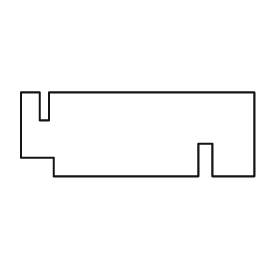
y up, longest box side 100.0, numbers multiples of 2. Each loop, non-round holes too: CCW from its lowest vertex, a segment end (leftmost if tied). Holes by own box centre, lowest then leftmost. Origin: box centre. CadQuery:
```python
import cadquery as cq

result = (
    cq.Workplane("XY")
    .moveTo(-36.0, -18.0)
    .lineTo(26.0, -18.0)
    .lineTo(26.0, -4.0)
    .lineTo(32.0, -4.0)
    .lineTo(32.0, -18.0)
    .lineTo(50.0, -18.0)
    .lineTo(50.0, 18.0)
    .lineTo(-38.0, 18.0)
    .lineTo(-38.0, 6.0)
    .lineTo(-42.0, 6.0)
    .lineTo(-42.0, 18.0)
    .lineTo(-50.0, 18.0)
    .lineTo(-50.0, -10.0)
    .lineTo(-36.0, -10.0)
    .close()
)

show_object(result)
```